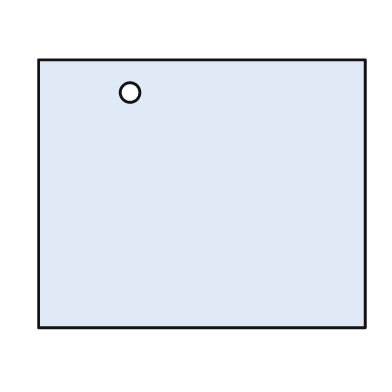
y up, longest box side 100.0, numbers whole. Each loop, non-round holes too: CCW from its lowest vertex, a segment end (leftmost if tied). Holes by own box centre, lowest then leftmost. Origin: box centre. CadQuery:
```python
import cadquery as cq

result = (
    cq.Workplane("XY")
    .moveTo(-50.0, -41.0)
    .lineTo(50.0, -41.0)
    .lineTo(50.0, 41.0)
    .lineTo(-50.0, 41.0)
    .close()
    .moveTo(-22.0, 31.0)
    .circle(3.0)
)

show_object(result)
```